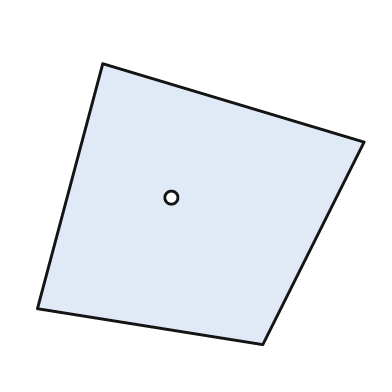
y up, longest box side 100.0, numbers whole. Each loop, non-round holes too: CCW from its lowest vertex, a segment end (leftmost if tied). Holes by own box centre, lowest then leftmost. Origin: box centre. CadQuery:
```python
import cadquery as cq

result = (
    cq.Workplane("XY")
    .moveTo(19.0, -43.0)
    .lineTo(50.0, 19.0)
    .lineTo(-30.0, 43.0)
    .lineTo(-50.0, -32.0)
    .close()
    .moveTo(-9.0, 2.0)
    .circle(2.0)
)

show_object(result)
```